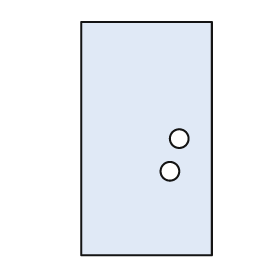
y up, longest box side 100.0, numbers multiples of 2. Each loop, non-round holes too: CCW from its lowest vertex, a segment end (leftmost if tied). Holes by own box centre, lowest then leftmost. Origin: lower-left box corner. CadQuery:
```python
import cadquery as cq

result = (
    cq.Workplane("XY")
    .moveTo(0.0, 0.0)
    .lineTo(56.0, 0.0)
    .lineTo(56.0, 100.0)
    .lineTo(0.0, 100.0)
    .close()
    .moveTo(38.0, 36.0)
    .circle(4.0)
    .moveTo(42.0, 50.0)
    .circle(4.0)
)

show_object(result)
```